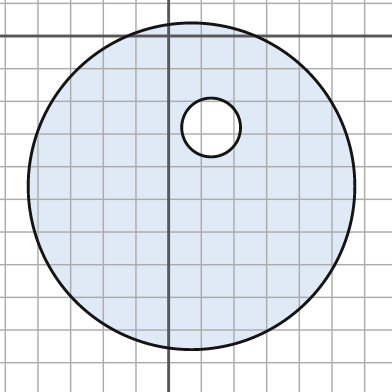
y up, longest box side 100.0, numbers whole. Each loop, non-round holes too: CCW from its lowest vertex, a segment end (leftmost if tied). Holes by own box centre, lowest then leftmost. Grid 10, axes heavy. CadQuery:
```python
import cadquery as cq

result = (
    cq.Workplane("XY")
    .moveTo(7.0, -46.0)
    .circle(50.0)
    .moveTo(13.0, -28.0)
    .circle(9.0)
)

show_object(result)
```